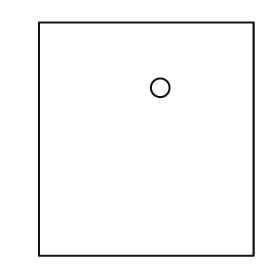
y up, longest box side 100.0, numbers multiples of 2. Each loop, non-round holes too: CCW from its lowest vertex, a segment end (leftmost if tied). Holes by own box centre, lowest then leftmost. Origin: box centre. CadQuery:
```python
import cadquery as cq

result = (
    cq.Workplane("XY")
    .moveTo(-46.0, -50.0)
    .lineTo(46.0, -50.0)
    .lineTo(46.0, 50.0)
    .lineTo(-46.0, 50.0)
    .close()
    .moveTo(6.0, 22.0)
    .circle(4.0)
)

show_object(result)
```